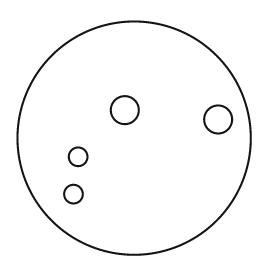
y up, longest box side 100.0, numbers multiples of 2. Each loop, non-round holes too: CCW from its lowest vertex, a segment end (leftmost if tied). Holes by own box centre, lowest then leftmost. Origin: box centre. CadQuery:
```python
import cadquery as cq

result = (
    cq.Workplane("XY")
    .moveTo(0.0, 0.0)
    .circle(50.0)
    .moveTo(-26.0, -24.0)
    .circle(4.0)
    .moveTo(-24.0, -8.0)
    .circle(4.0)
    .moveTo(36.0, 8.0)
    .circle(6.0)
    .moveTo(-4.0, 12.0)
    .circle(6.0)
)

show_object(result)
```